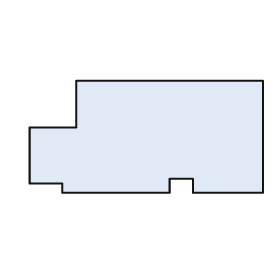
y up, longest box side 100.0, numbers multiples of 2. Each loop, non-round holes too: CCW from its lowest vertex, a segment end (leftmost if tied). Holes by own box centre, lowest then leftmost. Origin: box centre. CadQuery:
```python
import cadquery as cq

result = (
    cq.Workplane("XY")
    .moveTo(-36.0, -24.0)
    .lineTo(10.0, -24.0)
    .lineTo(10.0, -18.0)
    .lineTo(20.0, -18.0)
    .lineTo(20.0, -24.0)
    .lineTo(50.0, -24.0)
    .lineTo(50.0, 24.0)
    .lineTo(-30.0, 24.0)
    .lineTo(-30.0, 4.0)
    .lineTo(-50.0, 4.0)
    .lineTo(-50.0, -20.0)
    .lineTo(-36.0, -20.0)
    .close()
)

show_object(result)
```